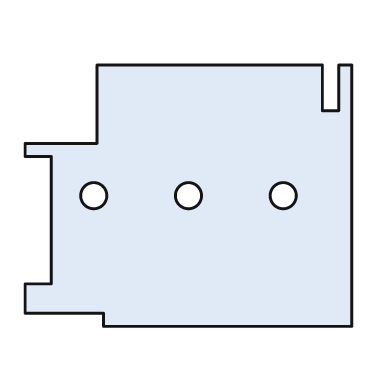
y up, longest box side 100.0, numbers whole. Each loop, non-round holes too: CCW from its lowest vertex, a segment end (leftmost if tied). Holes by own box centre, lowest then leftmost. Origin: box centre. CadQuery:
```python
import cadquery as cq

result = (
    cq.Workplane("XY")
    .moveTo(-26.0, -40.0)
    .lineTo(50.0, -40.0)
    .lineTo(50.0, 40.0)
    .lineTo(46.0, 40.0)
    .lineTo(46.0, 26.0)
    .lineTo(41.0, 26.0)
    .lineTo(41.0, 40.0)
    .lineTo(-28.0, 40.0)
    .lineTo(-28.0, 16.0)
    .lineTo(-50.0, 16.0)
    .lineTo(-50.0, 12.0)
    .lineTo(-42.0, 12.0)
    .lineTo(-42.0, -27.0)
    .lineTo(-50.0, -27.0)
    .lineTo(-50.0, -36.0)
    .lineTo(-26.0, -36.0)
    .close()
    .moveTo(-29.0, 0.0)
    .circle(4.0)
    .moveTo(0.0, 0.0)
    .circle(4.0)
    .moveTo(29.0, 0.0)
    .circle(4.0)
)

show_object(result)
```